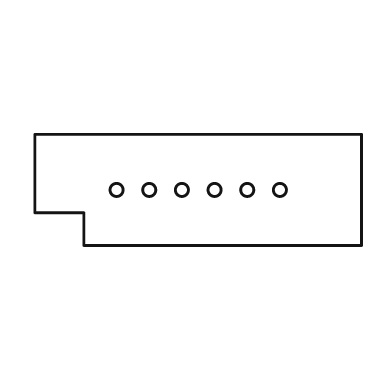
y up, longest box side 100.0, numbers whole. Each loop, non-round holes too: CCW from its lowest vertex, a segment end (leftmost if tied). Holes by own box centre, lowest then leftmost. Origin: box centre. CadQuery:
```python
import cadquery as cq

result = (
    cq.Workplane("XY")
    .moveTo(-35.0, -17.0)
    .lineTo(50.0, -17.0)
    .lineTo(50.0, 17.0)
    .lineTo(-50.0, 17.0)
    .lineTo(-50.0, -7.0)
    .lineTo(-35.0, -7.0)
    .close()
    .moveTo(-25.0, 0.0)
    .circle(2.0)
    .moveTo(-15.0, 0.0)
    .circle(2.0)
    .moveTo(-5.0, 0.0)
    .circle(2.0)
    .moveTo(5.0, 0.0)
    .circle(2.0)
    .moveTo(15.0, 0.0)
    .circle(2.0)
    .moveTo(25.0, 0.0)
    .circle(2.0)
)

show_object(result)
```